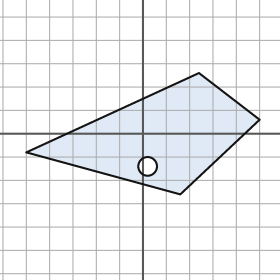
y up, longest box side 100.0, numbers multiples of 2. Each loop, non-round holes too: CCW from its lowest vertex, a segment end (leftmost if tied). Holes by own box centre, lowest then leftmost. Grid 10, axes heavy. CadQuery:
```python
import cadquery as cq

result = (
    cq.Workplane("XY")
    .moveTo(16.0, -26.0)
    .lineTo(50.0, 6.0)
    .lineTo(24.0, 26.0)
    .lineTo(-50.0, -8.0)
    .close()
    .moveTo(2.0, -14.0)
    .circle(4.0)
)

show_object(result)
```